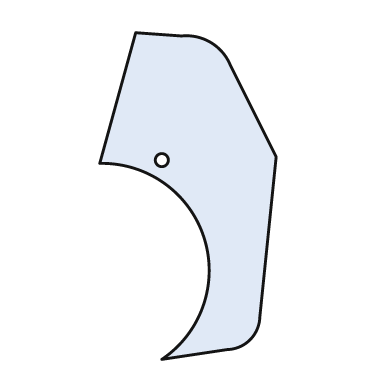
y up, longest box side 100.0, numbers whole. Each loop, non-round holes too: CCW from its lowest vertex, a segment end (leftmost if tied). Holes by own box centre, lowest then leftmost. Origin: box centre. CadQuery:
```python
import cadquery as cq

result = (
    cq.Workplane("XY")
    .moveTo(-8.0, -50.0)
    .lineTo(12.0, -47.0)
    .threePointArc((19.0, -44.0), (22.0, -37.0))
    .lineTo(27.0, 12.0)
    .lineTo(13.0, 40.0)
    .threePointArc((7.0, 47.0), (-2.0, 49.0))
    .lineTo(-16.0, 50.0)
    .lineTo(-27.0, 10.0)
    .threePointArc((5.0, -13.0), (-8.0, -50.0))
    .close()
    .moveTo(-8.0, 11.0)
    .circle(2.0)
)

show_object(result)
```